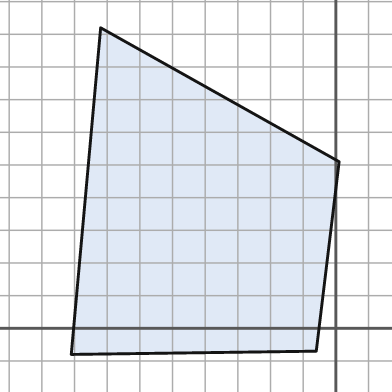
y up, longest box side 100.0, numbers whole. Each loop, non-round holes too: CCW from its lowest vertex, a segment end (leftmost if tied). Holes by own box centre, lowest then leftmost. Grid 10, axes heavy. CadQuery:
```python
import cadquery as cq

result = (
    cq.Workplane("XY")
    .moveTo(-81.0, -8.0)
    .lineTo(-6.0, -7.0)
    .lineTo(1.0, 51.0)
    .lineTo(-72.0, 92.0)
    .close()
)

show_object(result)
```